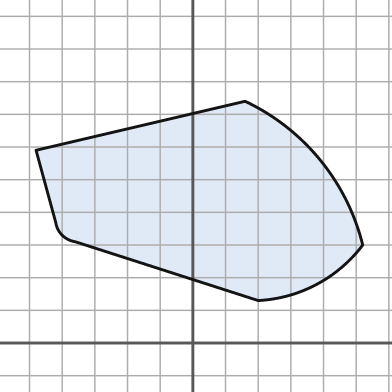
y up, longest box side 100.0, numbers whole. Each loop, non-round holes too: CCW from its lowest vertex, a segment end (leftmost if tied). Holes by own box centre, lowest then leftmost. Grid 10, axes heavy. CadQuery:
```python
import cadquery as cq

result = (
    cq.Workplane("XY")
    .moveTo(20.0, 13.0)
    .threePointArc((38.0, 18.0), (52.0, 30.0))
    .threePointArc((39.0, 56.0), (16.0, 74.0))
    .lineTo(-48.0, 59.0)
    .lineTo(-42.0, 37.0)
    .threePointArc((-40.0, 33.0), (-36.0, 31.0))
    .close()
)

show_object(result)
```